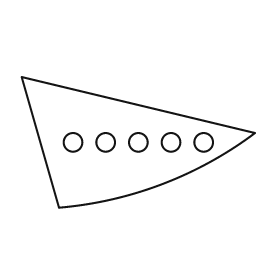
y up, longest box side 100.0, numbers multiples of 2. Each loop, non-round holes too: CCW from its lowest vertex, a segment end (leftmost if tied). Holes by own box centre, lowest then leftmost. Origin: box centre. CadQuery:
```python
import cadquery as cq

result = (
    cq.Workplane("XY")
    .moveTo(-34.0, -28.0)
    .threePointArc((10.0, -18.0), (50.0, 4.0))
    .lineTo(-50.0, 28.0)
    .close()
    .moveTo(-28.0, 0.0)
    .circle(4.0)
    .moveTo(-14.0, 0.0)
    .circle(4.0)
    .moveTo(0.0, 0.0)
    .circle(4.0)
    .moveTo(14.0, 0.0)
    .circle(4.0)
    .moveTo(28.0, 0.0)
    .circle(4.0)
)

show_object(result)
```